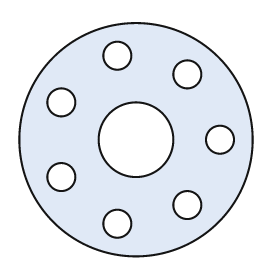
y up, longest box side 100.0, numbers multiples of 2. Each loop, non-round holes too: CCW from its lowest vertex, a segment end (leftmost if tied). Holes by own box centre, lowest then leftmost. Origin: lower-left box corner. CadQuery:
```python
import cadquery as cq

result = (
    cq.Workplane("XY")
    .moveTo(50.0, 50.0)
    .circle(50.0)
    .moveTo(42.0, 14.0)
    .circle(6.0)
    .moveTo(72.0, 22.0)
    .circle(6.0)
    .moveTo(18.0, 34.0)
    .circle(6.0)
    .moveTo(50.0, 50.0)
    .circle(16.0)
    .moveTo(86.0, 50.0)
    .circle(6.0)
    .moveTo(18.0, 66.0)
    .circle(6.0)
    .moveTo(72.0, 78.0)
    .circle(6.0)
    .moveTo(42.0, 86.0)
    .circle(6.0)
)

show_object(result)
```